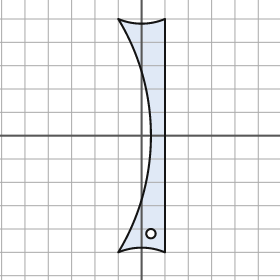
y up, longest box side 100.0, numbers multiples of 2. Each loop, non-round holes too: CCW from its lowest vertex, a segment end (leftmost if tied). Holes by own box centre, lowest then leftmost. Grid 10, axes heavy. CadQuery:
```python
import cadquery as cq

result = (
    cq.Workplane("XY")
    .moveTo(-10.0, -50.0)
    .threePointArc((0.0, -48.0), (10.0, -50.0))
    .lineTo(10.0, 50.0)
    .threePointArc((0.0, 48.0), (-10.0, 50.0))
    .threePointArc((4.0, 0.0), (-10.0, -50.0))
    .close()
    .moveTo(4.0, -42.0)
    .circle(2.0)
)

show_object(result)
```